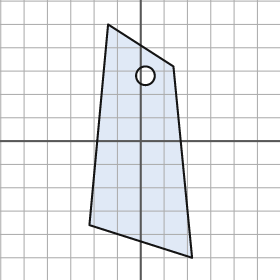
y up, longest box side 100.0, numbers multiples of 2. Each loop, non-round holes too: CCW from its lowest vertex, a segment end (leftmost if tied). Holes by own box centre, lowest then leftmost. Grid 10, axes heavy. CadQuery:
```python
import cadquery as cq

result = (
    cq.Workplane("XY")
    .moveTo(22.0, -50.0)
    .lineTo(14.0, 32.0)
    .lineTo(-14.0, 50.0)
    .lineTo(-22.0, -36.0)
    .close()
    .moveTo(2.0, 28.0)
    .circle(4.0)
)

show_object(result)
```